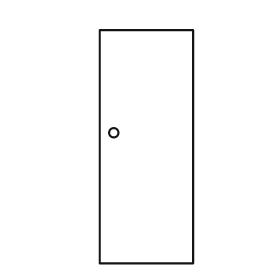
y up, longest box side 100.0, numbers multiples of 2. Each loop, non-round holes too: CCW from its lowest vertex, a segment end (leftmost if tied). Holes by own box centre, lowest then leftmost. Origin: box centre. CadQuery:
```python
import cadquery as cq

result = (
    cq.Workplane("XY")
    .moveTo(-20.0, -50.0)
    .lineTo(20.0, -50.0)
    .lineTo(20.0, 50.0)
    .lineTo(-20.0, 50.0)
    .close()
    .moveTo(-14.0, 6.0)
    .circle(2.0)
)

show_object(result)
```